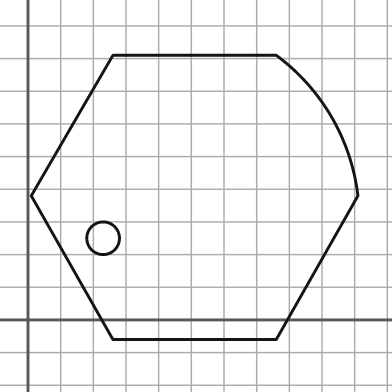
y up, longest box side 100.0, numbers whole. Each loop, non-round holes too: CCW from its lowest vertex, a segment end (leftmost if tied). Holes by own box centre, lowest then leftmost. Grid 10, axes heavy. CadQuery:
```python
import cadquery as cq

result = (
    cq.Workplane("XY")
    .moveTo(26.0, -6.0)
    .lineTo(76.0, -6.0)
    .lineTo(101.0, 38.0)
    .threePointArc((93.0, 62.0), (76.0, 81.0))
    .lineTo(26.0, 81.0)
    .lineTo(1.0, 38.0)
    .close()
    .moveTo(23.0, 25.0)
    .circle(5.0)
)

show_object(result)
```